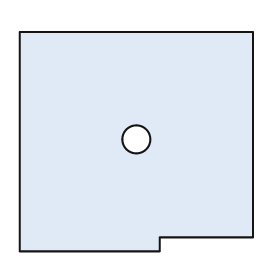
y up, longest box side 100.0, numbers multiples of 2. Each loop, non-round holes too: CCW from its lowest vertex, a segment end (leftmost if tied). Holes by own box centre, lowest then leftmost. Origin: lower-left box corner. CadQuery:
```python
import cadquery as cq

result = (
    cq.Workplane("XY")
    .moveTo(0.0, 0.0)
    .lineTo(60.0, 0.0)
    .lineTo(60.0, 6.0)
    .lineTo(100.0, 6.0)
    .lineTo(100.0, 94.0)
    .lineTo(0.0, 94.0)
    .close()
    .moveTo(50.0, 48.0)
    .circle(6.0)
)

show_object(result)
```